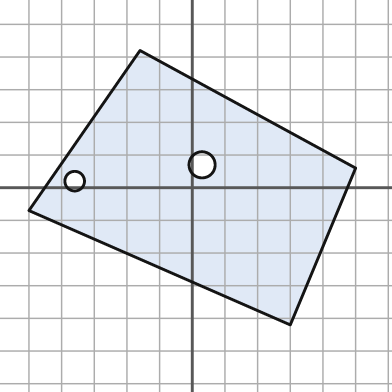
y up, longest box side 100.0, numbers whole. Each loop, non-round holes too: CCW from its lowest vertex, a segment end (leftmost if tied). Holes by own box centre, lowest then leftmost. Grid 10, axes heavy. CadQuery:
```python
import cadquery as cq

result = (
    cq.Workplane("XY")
    .moveTo(30.0, -42.0)
    .lineTo(50.0, 6.0)
    .lineTo(-16.0, 42.0)
    .lineTo(-50.0, -7.0)
    .close()
    .moveTo(-36.0, 2.0)
    .circle(3.0)
    .moveTo(3.0, 7.0)
    .circle(4.0)
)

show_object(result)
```